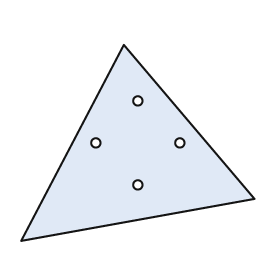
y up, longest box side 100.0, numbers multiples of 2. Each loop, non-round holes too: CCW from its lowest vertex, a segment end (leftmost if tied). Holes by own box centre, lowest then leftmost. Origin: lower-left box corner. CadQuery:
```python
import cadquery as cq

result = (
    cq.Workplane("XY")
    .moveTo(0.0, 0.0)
    .lineTo(100.0, 18.0)
    .lineTo(44.0, 84.0)
    .close()
    .moveTo(50.0, 24.0)
    .circle(2.0)
    .moveTo(32.0, 42.0)
    .circle(2.0)
    .moveTo(68.0, 42.0)
    .circle(2.0)
    .moveTo(50.0, 60.0)
    .circle(2.0)
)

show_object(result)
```